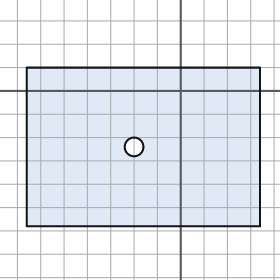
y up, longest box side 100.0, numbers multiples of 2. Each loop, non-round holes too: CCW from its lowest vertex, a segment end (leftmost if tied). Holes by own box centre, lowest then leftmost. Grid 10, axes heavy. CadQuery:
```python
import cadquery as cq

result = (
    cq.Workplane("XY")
    .moveTo(-66.0, -58.0)
    .lineTo(34.0, -58.0)
    .lineTo(34.0, 10.0)
    .lineTo(-66.0, 10.0)
    .close()
    .moveTo(-20.0, -24.0)
    .circle(4.0)
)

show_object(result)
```